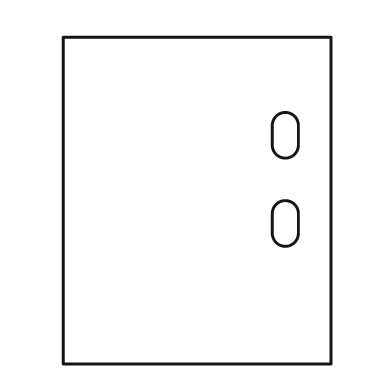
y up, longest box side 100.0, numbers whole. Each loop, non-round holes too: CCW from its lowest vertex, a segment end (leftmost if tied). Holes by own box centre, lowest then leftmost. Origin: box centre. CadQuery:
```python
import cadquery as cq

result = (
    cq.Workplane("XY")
    .moveTo(-41.0, -50.0)
    .lineTo(41.0, -50.0)
    .lineTo(41.0, 50.0)
    .lineTo(-41.0, 50.0)
    .close()
    .moveTo(23.0, -10.0)
    .threePointArc((27.0, -14.0), (31.0, -10.0))
    .lineTo(31.0, -4.0)
    .threePointArc((27.0, 0.0), (23.0, -4.0))
    .close()
    .moveTo(23.0, 17.0)
    .threePointArc((27.0, 13.0), (31.0, 17.0))
    .lineTo(31.0, 23.0)
    .threePointArc((27.0, 27.0), (23.0, 23.0))
    .close()
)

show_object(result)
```